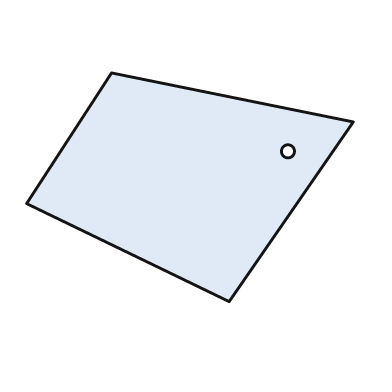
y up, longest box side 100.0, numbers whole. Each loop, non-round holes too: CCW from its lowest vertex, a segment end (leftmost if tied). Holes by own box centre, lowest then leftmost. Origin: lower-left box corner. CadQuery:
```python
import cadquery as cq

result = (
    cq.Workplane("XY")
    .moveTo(62.0, 0.0)
    .lineTo(100.0, 55.0)
    .lineTo(26.0, 70.0)
    .lineTo(0.0, 30.0)
    .close()
    .moveTo(80.0, 46.0)
    .circle(2.0)
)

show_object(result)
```